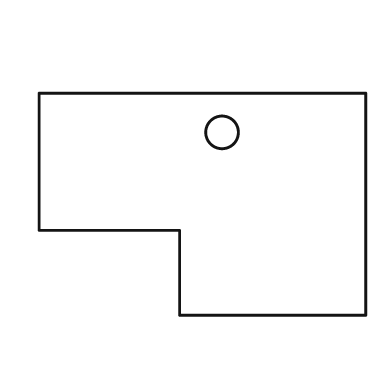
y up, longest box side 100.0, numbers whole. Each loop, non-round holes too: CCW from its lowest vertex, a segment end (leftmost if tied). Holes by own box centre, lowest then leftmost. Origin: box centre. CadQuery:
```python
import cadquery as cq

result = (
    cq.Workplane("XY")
    .moveTo(-7.0, -34.0)
    .lineTo(50.0, -34.0)
    .lineTo(50.0, 34.0)
    .lineTo(-50.0, 34.0)
    .lineTo(-50.0, -8.0)
    .lineTo(-7.0, -8.0)
    .close()
    .moveTo(6.0, 22.0)
    .circle(5.0)
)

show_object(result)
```